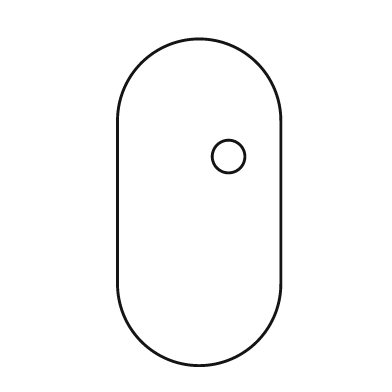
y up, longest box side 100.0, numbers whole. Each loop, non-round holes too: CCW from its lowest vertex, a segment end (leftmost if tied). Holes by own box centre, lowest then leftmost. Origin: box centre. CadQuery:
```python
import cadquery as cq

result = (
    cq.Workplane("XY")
    .moveTo(-25.0, -25.0)
    .threePointArc((0.0, -50.0), (25.0, -25.0))
    .lineTo(25.0, 25.0)
    .threePointArc((0.0, 50.0), (-25.0, 25.0))
    .close()
    .moveTo(9.0, 14.0)
    .circle(5.0)
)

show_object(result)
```